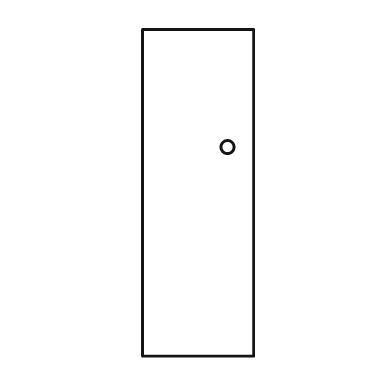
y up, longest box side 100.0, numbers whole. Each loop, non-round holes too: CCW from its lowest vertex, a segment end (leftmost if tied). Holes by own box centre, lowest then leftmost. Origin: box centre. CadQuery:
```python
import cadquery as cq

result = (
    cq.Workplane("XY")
    .moveTo(-17.0, -50.0)
    .lineTo(17.0, -50.0)
    .lineTo(17.0, 50.0)
    .lineTo(-17.0, 50.0)
    .close()
    .moveTo(9.0, 14.0)
    .circle(2.0)
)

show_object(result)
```